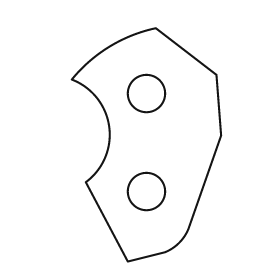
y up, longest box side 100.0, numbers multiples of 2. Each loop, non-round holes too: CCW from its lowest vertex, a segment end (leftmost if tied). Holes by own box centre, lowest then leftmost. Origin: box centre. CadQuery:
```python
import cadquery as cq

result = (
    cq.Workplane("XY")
    .moveTo(-8.0, -50.0)
    .lineTo(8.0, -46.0)
    .threePointArc((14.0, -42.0), (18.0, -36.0))
    .lineTo(32.0, 4.0)
    .lineTo(30.0, 30.0)
    .lineTo(4.0, 50.0)
    .threePointArc((-16.0, 42.0), (-32.0, 28.0))
    .threePointArc((-16.0, 8.0), (-26.0, -16.0))
    .close()
    .moveTo(0.0, -20.0)
    .circle(8.0)
    .moveTo(0.0, 22.0)
    .circle(8.0)
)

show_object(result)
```